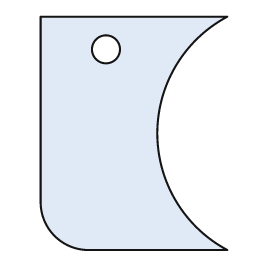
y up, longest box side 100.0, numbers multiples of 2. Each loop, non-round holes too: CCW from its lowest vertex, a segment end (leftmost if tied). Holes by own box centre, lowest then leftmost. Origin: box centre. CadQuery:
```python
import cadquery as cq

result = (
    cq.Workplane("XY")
    .moveTo(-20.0, -50.0)
    .lineTo(40.0, -50.0)
    .threePointArc((10.0, 0.0), (40.0, 50.0))
    .lineTo(-40.0, 50.0)
    .lineTo(-40.0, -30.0)
    .threePointArc((-34.0, -44.0), (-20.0, -50.0))
    .close()
    .moveTo(-12.0, 36.0)
    .circle(6.0)
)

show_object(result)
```